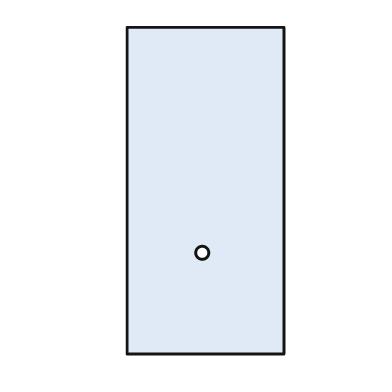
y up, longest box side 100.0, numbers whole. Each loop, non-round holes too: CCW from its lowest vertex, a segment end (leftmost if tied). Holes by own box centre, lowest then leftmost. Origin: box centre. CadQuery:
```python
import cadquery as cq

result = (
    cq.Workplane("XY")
    .moveTo(-24.0, -50.0)
    .lineTo(24.0, -50.0)
    .lineTo(24.0, 50.0)
    .lineTo(-24.0, 50.0)
    .close()
    .moveTo(-1.0, -19.0)
    .circle(2.0)
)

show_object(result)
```